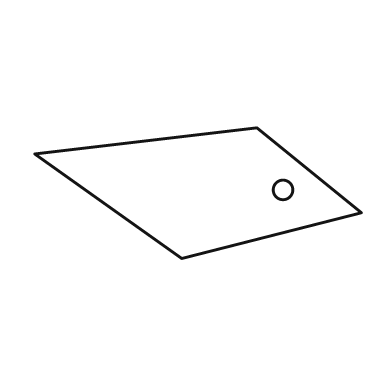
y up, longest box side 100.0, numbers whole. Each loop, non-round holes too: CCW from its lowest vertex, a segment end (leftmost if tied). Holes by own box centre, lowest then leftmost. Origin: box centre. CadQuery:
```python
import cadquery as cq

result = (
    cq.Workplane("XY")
    .moveTo(-5.0, -20.0)
    .lineTo(50.0, -6.0)
    .lineTo(18.0, 20.0)
    .lineTo(-50.0, 12.0)
    .close()
    .moveTo(26.0, 1.0)
    .circle(3.0)
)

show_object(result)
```